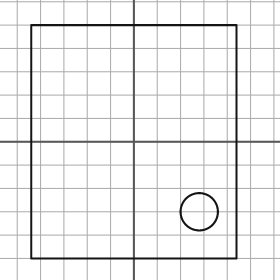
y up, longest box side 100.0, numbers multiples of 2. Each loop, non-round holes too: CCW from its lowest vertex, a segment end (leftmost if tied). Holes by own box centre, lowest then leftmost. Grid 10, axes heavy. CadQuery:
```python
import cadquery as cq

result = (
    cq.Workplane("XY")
    .moveTo(-44.0, -50.0)
    .lineTo(44.0, -50.0)
    .lineTo(44.0, 50.0)
    .lineTo(-44.0, 50.0)
    .close()
    .moveTo(28.0, -30.0)
    .circle(8.0)
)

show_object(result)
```